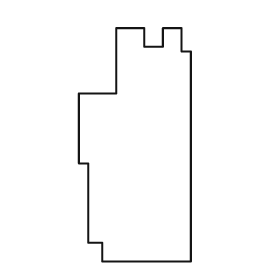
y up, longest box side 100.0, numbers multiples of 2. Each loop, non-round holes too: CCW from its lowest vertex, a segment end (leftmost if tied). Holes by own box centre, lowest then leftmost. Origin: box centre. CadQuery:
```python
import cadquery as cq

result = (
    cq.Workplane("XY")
    .moveTo(-14.0, -50.0)
    .lineTo(24.0, -50.0)
    .lineTo(24.0, 40.0)
    .lineTo(20.0, 40.0)
    .lineTo(20.0, 50.0)
    .lineTo(12.0, 50.0)
    .lineTo(12.0, 42.0)
    .lineTo(4.0, 42.0)
    .lineTo(4.0, 50.0)
    .lineTo(-8.0, 50.0)
    .lineTo(-8.0, 22.0)
    .lineTo(-24.0, 22.0)
    .lineTo(-24.0, -8.0)
    .lineTo(-20.0, -8.0)
    .lineTo(-20.0, -42.0)
    .lineTo(-14.0, -42.0)
    .close()
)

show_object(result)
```